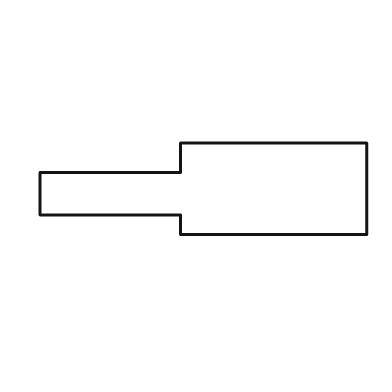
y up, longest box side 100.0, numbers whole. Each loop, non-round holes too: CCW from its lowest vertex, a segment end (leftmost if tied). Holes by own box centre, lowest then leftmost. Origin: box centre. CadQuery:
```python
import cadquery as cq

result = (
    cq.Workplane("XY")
    .moveTo(-7.0, -14.0)
    .lineTo(50.0, -14.0)
    .lineTo(50.0, 14.0)
    .lineTo(-7.0, 14.0)
    .lineTo(-7.0, 5.0)
    .lineTo(-50.0, 5.0)
    .lineTo(-50.0, -8.0)
    .lineTo(-7.0, -8.0)
    .close()
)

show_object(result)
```